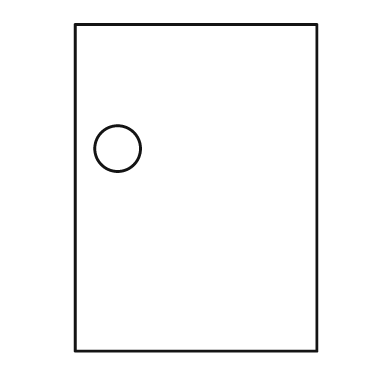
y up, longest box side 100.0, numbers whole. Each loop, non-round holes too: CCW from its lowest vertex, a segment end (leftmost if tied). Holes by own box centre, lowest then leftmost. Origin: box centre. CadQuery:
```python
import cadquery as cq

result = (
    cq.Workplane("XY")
    .moveTo(-37.0, -50.0)
    .lineTo(37.0, -50.0)
    .lineTo(37.0, 50.0)
    .lineTo(-37.0, 50.0)
    .close()
    .moveTo(-24.0, 12.0)
    .circle(7.0)
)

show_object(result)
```